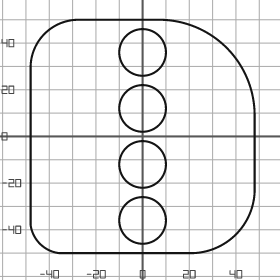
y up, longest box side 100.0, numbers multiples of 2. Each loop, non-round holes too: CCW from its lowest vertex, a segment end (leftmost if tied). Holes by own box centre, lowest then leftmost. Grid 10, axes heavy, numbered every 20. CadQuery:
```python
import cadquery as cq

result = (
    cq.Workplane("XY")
    .moveTo(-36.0, -50.0)
    .lineTo(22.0, -50.0)
    .threePointArc((40.0, -42.0), (48.0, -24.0))
    .lineTo(48.0, 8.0)
    .threePointArc((36.0, 38.0), (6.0, 50.0))
    .lineTo(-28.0, 50.0)
    .threePointArc((-42.0, 44.0), (-48.0, 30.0))
    .lineTo(-48.0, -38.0)
    .threePointArc((-44.0, -46.0), (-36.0, -50.0))
    .close()
    .moveTo(0.0, -36.0)
    .circle(10.0)
    .moveTo(0.0, -12.0)
    .circle(10.0)
    .moveTo(0.0, 12.0)
    .circle(10.0)
    .moveTo(0.0, 36.0)
    .circle(10.0)
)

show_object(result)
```